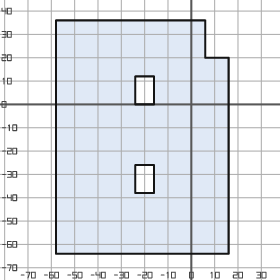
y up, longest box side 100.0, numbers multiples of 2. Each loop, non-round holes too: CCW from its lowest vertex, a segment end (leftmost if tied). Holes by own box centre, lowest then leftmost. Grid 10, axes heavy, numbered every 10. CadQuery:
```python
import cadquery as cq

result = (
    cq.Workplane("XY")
    .moveTo(-58.0, -64.0)
    .lineTo(16.0, -64.0)
    .lineTo(16.0, 20.0)
    .lineTo(6.0, 20.0)
    .lineTo(6.0, 36.0)
    .lineTo(-58.0, 36.0)
    .close()
    .moveTo(-24.0, -38.0)
    .lineTo(-16.0, -38.0)
    .lineTo(-16.0, -26.0)
    .lineTo(-24.0, -26.0)
    .close()
    .moveTo(-24.0, 0.0)
    .lineTo(-16.0, 0.0)
    .lineTo(-16.0, 12.0)
    .lineTo(-24.0, 12.0)
    .close()
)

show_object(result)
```